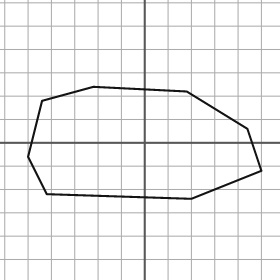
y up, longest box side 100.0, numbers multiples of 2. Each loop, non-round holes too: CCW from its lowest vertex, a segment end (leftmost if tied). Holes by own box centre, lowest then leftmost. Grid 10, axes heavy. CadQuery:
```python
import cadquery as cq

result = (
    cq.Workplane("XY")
    .moveTo(20.0, -24.0)
    .lineTo(50.0, -12.0)
    .lineTo(44.0, 6.0)
    .lineTo(18.0, 22.0)
    .lineTo(-22.0, 24.0)
    .lineTo(-44.0, 18.0)
    .lineTo(-50.0, -6.0)
    .lineTo(-42.0, -22.0)
    .close()
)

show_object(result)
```